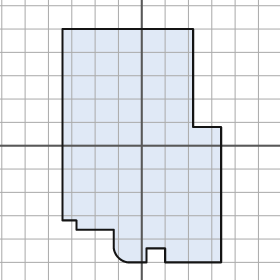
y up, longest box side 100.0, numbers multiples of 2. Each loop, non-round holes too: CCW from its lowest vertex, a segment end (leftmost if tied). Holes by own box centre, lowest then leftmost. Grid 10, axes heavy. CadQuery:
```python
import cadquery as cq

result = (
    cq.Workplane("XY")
    .moveTo(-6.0, -50.0)
    .lineTo(2.0, -50.0)
    .lineTo(2.0, -44.0)
    .lineTo(10.0, -44.0)
    .lineTo(10.0, -50.0)
    .lineTo(34.0, -50.0)
    .lineTo(34.0, 8.0)
    .lineTo(22.0, 8.0)
    .lineTo(22.0, 50.0)
    .lineTo(-34.0, 50.0)
    .lineTo(-34.0, -32.0)
    .lineTo(-28.0, -32.0)
    .lineTo(-28.0, -36.0)
    .lineTo(-12.0, -36.0)
    .lineTo(-12.0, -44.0)
    .threePointArc((-10.0, -48.0), (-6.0, -50.0))
    .close()
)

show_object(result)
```